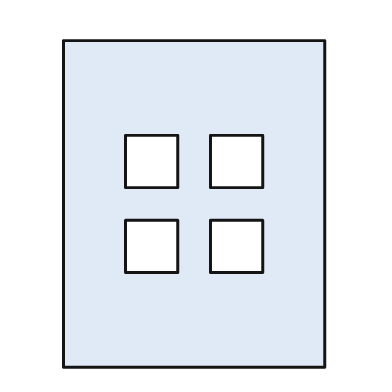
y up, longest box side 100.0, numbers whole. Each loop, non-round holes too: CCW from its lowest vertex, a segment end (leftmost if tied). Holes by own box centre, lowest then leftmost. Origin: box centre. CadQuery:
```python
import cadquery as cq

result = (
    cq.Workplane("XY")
    .moveTo(-40.0, -50.0)
    .lineTo(40.0, -50.0)
    .lineTo(40.0, 50.0)
    .lineTo(-40.0, 50.0)
    .close()
    .moveTo(-21.0, -21.0)
    .lineTo(-5.0, -21.0)
    .lineTo(-5.0, -5.0)
    .lineTo(-21.0, -5.0)
    .close()
    .moveTo(5.0, -21.0)
    .lineTo(21.0, -21.0)
    .lineTo(21.0, -5.0)
    .lineTo(5.0, -5.0)
    .close()
    .moveTo(-21.0, 5.0)
    .lineTo(-5.0, 5.0)
    .lineTo(-5.0, 21.0)
    .lineTo(-21.0, 21.0)
    .close()
    .moveTo(5.0, 5.0)
    .lineTo(21.0, 5.0)
    .lineTo(21.0, 21.0)
    .lineTo(5.0, 21.0)
    .close()
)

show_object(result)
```